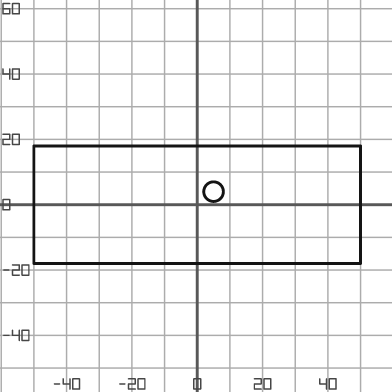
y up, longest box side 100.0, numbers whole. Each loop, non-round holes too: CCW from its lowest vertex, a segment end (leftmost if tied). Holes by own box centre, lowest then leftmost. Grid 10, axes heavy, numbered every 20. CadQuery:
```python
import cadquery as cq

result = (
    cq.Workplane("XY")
    .moveTo(-50.0, -18.0)
    .lineTo(50.0, -18.0)
    .lineTo(50.0, 18.0)
    .lineTo(-50.0, 18.0)
    .close()
    .moveTo(5.0, 4.0)
    .circle(3.0)
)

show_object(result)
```